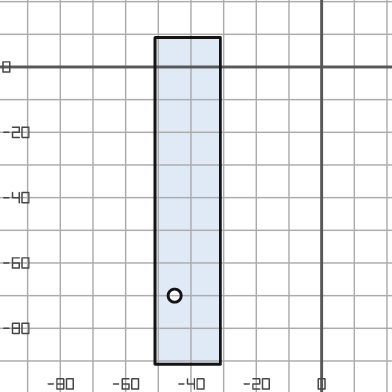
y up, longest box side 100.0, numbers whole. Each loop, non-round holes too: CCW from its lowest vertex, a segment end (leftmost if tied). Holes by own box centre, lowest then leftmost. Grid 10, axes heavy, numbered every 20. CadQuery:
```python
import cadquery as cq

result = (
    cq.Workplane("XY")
    .moveTo(-51.0, -91.0)
    .lineTo(-31.0, -91.0)
    .lineTo(-31.0, 9.0)
    .lineTo(-51.0, 9.0)
    .close()
    .moveTo(-45.0, -70.0)
    .circle(2.0)
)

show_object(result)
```